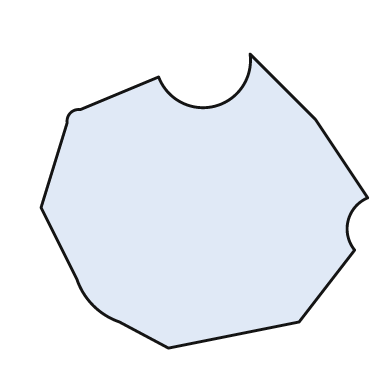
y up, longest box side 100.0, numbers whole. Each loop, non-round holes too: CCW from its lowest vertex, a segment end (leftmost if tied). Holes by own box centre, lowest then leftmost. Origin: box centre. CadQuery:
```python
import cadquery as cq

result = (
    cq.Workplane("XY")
    .moveTo(-11.0, -45.0)
    .lineTo(29.0, -37.0)
    .lineTo(46.0, -15.0)
    .threePointArc((44.0, -6.0), (50.0, 1.0))
    .lineTo(34.0, 25.0)
    .lineTo(14.0, 45.0)
    .threePointArc((3.0, 29.0), (-14.0, 38.0))
    .lineTo(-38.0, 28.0)
    .threePointArc((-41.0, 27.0), (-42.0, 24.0))
    .lineTo(-50.0, -2.0)
    .lineTo(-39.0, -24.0)
    .threePointArc((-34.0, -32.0), (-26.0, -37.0))
    .close()
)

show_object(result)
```